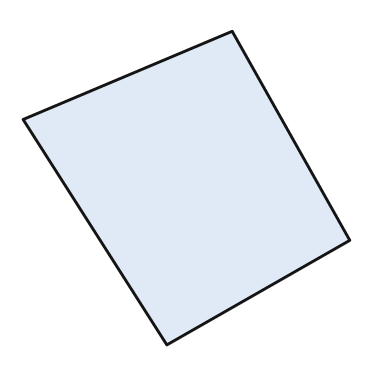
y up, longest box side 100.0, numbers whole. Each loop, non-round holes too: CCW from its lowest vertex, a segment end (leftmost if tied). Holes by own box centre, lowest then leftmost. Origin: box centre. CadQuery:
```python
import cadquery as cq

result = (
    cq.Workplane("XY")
    .moveTo(-6.0, -48.0)
    .lineTo(50.0, -16.0)
    .lineTo(14.0, 48.0)
    .lineTo(-50.0, 21.0)
    .close()
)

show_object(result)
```